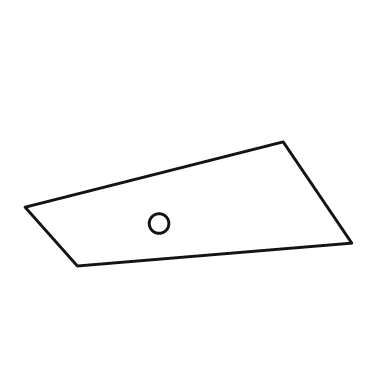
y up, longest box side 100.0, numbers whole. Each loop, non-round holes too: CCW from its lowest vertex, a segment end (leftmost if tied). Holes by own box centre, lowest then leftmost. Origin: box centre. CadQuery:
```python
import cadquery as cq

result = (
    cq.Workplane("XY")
    .moveTo(-34.0, -19.0)
    .lineTo(50.0, -12.0)
    .lineTo(29.0, 19.0)
    .lineTo(-50.0, -1.0)
    .close()
    .moveTo(-9.0, -6.0)
    .circle(3.0)
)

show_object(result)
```